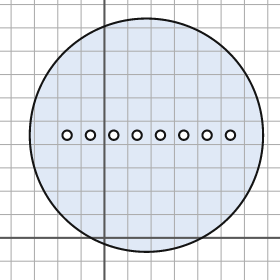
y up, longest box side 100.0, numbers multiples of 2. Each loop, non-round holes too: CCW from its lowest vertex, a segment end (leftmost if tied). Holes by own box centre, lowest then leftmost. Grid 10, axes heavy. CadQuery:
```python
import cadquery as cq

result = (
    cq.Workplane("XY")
    .moveTo(18.0, 44.0)
    .circle(50.0)
    .moveTo(-16.0, 44.0)
    .circle(2.0)
    .moveTo(-6.0, 44.0)
    .circle(2.0)
    .moveTo(4.0, 44.0)
    .circle(2.0)
    .moveTo(14.0, 44.0)
    .circle(2.0)
    .moveTo(24.0, 44.0)
    .circle(2.0)
    .moveTo(34.0, 44.0)
    .circle(2.0)
    .moveTo(44.0, 44.0)
    .circle(2.0)
    .moveTo(54.0, 44.0)
    .circle(2.0)
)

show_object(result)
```